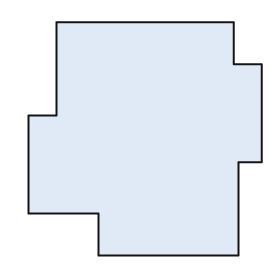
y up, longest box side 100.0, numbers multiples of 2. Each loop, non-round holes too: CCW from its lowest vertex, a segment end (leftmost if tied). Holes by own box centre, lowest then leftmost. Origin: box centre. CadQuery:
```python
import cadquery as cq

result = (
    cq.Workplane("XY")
    .moveTo(-20.0, -50.0)
    .lineTo(40.0, -50.0)
    .lineTo(40.0, -10.0)
    .lineTo(50.0, -10.0)
    .lineTo(50.0, 32.0)
    .lineTo(38.0, 32.0)
    .lineTo(38.0, 50.0)
    .lineTo(-38.0, 50.0)
    .lineTo(-38.0, 10.0)
    .lineTo(-50.0, 10.0)
    .lineTo(-50.0, -32.0)
    .lineTo(-20.0, -32.0)
    .close()
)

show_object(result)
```